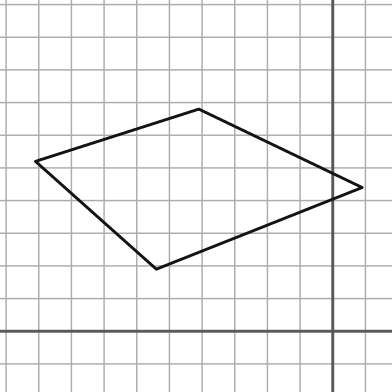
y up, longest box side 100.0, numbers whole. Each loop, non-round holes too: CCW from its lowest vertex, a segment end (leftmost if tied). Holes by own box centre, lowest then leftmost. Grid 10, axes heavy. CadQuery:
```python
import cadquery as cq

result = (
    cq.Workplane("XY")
    .moveTo(-54.0, 19.0)
    .lineTo(9.0, 44.0)
    .lineTo(-41.0, 68.0)
    .lineTo(-91.0, 52.0)
    .close()
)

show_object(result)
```